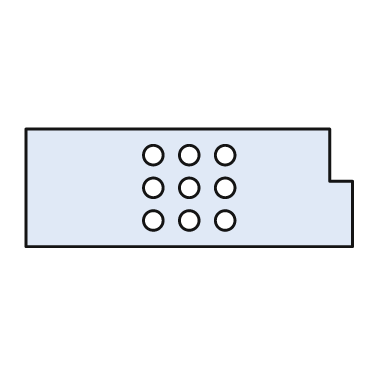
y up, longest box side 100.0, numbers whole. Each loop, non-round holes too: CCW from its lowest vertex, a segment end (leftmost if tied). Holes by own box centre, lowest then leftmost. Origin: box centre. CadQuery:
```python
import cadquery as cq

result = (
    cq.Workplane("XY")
    .moveTo(-50.0, -18.0)
    .lineTo(50.0, -18.0)
    .lineTo(50.0, 2.0)
    .lineTo(43.0, 2.0)
    .lineTo(43.0, 18.0)
    .lineTo(-50.0, 18.0)
    .close()
    .moveTo(-11.0, -10.0)
    .circle(3.0)
    .moveTo(0.0, -10.0)
    .circle(3.0)
    .moveTo(11.0, -10.0)
    .circle(3.0)
    .moveTo(-11.0, 0.0)
    .circle(3.0)
    .moveTo(0.0, 0.0)
    .circle(3.0)
    .moveTo(11.0, 0.0)
    .circle(3.0)
    .moveTo(-11.0, 10.0)
    .circle(3.0)
    .moveTo(0.0, 10.0)
    .circle(3.0)
    .moveTo(11.0, 10.0)
    .circle(3.0)
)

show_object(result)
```